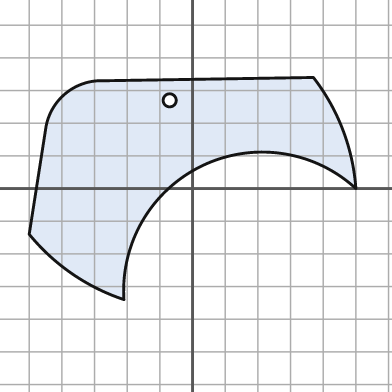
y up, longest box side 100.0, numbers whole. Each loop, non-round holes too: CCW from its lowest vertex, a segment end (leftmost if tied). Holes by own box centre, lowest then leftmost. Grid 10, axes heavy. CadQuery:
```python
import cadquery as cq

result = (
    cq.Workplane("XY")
    .moveTo(-21.0, -34.0)
    .threePointArc((3.0, 7.0), (50.0, 0.0))
    .threePointArc((46.0, 18.0), (37.0, 34.0))
    .lineTo(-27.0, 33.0)
    .threePointArc((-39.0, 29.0), (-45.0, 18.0))
    .lineTo(-50.0, -14.0)
    .threePointArc((-37.0, -26.0), (-21.0, -34.0))
    .close()
    .moveTo(-7.0, 27.0)
    .circle(2.0)
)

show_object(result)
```